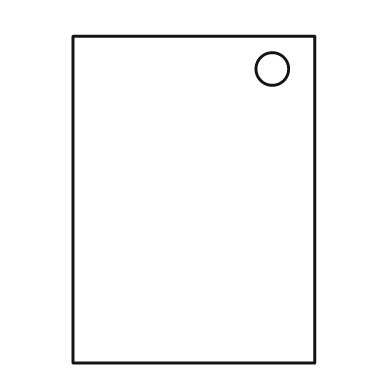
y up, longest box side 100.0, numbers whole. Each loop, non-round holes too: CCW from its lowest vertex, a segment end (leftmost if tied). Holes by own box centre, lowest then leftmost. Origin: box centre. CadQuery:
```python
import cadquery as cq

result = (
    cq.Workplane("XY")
    .moveTo(-37.0, -50.0)
    .lineTo(37.0, -50.0)
    .lineTo(37.0, 50.0)
    .lineTo(-37.0, 50.0)
    .close()
    .moveTo(24.0, 40.0)
    .circle(5.0)
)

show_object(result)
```